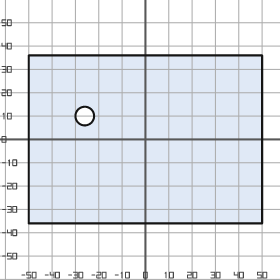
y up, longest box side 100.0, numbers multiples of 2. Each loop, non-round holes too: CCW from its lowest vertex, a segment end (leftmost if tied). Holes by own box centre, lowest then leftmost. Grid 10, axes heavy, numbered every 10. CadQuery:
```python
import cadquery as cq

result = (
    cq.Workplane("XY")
    .moveTo(-50.0, -36.0)
    .lineTo(50.0, -36.0)
    .lineTo(50.0, 36.0)
    .lineTo(-50.0, 36.0)
    .close()
    .moveTo(-26.0, 10.0)
    .circle(4.0)
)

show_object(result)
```